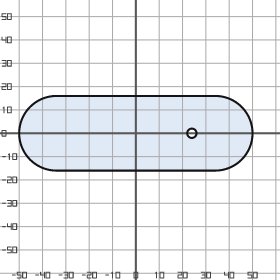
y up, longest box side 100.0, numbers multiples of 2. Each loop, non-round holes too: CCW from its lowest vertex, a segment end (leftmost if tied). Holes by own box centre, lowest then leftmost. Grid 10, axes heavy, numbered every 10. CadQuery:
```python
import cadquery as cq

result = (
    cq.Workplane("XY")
    .moveTo(-34.0, -16.0)
    .lineTo(34.0, -16.0)
    .threePointArc((50.0, 0.0), (34.0, 16.0))
    .lineTo(-34.0, 16.0)
    .threePointArc((-50.0, 0.0), (-34.0, -16.0))
    .close()
    .moveTo(24.0, 0.0)
    .circle(2.0)
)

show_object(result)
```